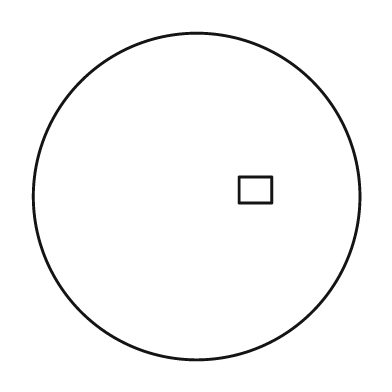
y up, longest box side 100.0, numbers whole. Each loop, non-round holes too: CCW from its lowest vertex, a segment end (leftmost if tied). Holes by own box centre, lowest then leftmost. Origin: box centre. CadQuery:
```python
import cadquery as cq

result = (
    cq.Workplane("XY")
    .moveTo(0.0, 0.0)
    .circle(50.0)
    .moveTo(13.0, -2.0)
    .lineTo(23.0, -2.0)
    .lineTo(23.0, 6.0)
    .lineTo(13.0, 6.0)
    .close()
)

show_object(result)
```